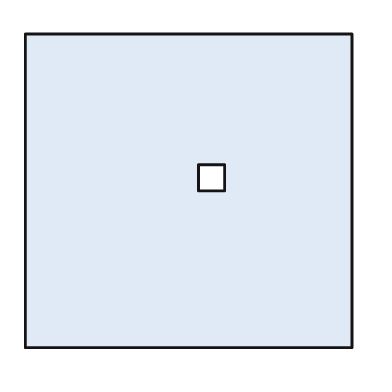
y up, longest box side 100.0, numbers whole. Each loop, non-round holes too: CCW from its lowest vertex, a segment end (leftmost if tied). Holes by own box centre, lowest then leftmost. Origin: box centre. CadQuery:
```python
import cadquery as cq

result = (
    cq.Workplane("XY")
    .moveTo(-50.0, -48.0)
    .lineTo(50.0, -48.0)
    .lineTo(50.0, 48.0)
    .lineTo(-50.0, 48.0)
    .close()
    .moveTo(3.0, 0.0)
    .lineTo(11.0, 0.0)
    .lineTo(11.0, 8.0)
    .lineTo(3.0, 8.0)
    .close()
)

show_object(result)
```